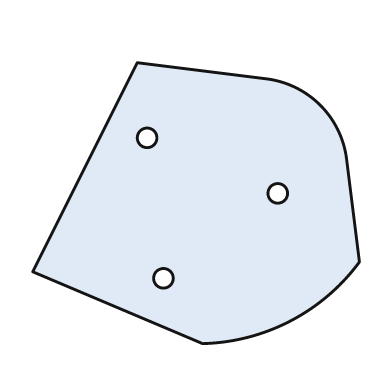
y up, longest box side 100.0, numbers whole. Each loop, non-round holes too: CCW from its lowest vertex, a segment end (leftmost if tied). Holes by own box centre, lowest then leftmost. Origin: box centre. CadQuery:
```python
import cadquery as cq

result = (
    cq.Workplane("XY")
    .moveTo(2.0, -43.0)
    .threePointArc((29.0, -36.0), (50.0, -18.0))
    .lineTo(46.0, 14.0)
    .threePointArc((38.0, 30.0), (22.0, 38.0))
    .lineTo(-18.0, 43.0)
    .lineTo(-50.0, -21.0)
    .close()
    .moveTo(-10.0, -23.0)
    .circle(3.0)
    .moveTo(25.0, 3.0)
    .circle(3.0)
    .moveTo(-15.0, 20.0)
    .circle(3.0)
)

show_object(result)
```